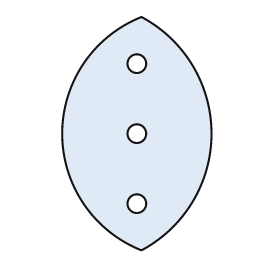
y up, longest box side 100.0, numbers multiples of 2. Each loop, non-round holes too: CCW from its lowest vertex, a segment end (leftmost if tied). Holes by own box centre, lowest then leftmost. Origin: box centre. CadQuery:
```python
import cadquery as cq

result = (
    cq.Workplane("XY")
    .moveTo(2.0, -50.0)
    .threePointArc((32.0, 0.0), (2.0, 50.0))
    .threePointArc((-32.0, 0.0), (2.0, -50.0))
    .close()
    .moveTo(0.0, -30.0)
    .circle(4.0)
    .moveTo(0.0, 0.0)
    .circle(4.0)
    .moveTo(0.0, 30.0)
    .circle(4.0)
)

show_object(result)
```